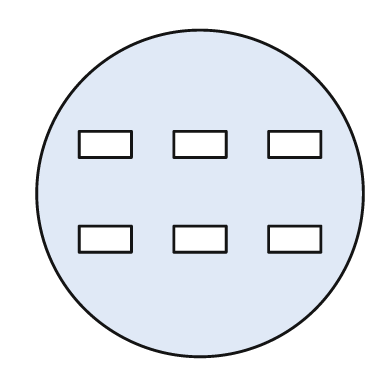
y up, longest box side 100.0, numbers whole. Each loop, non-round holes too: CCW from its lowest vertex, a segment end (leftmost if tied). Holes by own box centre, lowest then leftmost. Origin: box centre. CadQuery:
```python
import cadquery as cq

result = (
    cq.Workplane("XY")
    .moveTo(0.0, 0.0)
    .circle(50.0)
    .moveTo(-37.0, -18.0)
    .lineTo(-21.0, -18.0)
    .lineTo(-21.0, -10.0)
    .lineTo(-37.0, -10.0)
    .close()
    .moveTo(-8.0, -18.0)
    .lineTo(8.0, -18.0)
    .lineTo(8.0, -10.0)
    .lineTo(-8.0, -10.0)
    .close()
    .moveTo(21.0, -18.0)
    .lineTo(37.0, -18.0)
    .lineTo(37.0, -10.0)
    .lineTo(21.0, -10.0)
    .close()
    .moveTo(-37.0, 11.0)
    .lineTo(-21.0, 11.0)
    .lineTo(-21.0, 19.0)
    .lineTo(-37.0, 19.0)
    .close()
    .moveTo(-8.0, 11.0)
    .lineTo(8.0, 11.0)
    .lineTo(8.0, 19.0)
    .lineTo(-8.0, 19.0)
    .close()
    .moveTo(21.0, 11.0)
    .lineTo(37.0, 11.0)
    .lineTo(37.0, 19.0)
    .lineTo(21.0, 19.0)
    .close()
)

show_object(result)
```